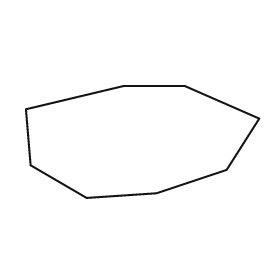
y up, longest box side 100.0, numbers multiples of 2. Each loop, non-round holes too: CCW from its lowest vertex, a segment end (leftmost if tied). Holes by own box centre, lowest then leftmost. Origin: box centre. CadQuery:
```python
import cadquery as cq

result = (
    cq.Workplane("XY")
    .moveTo(-24.0, -24.0)
    .lineTo(6.0, -22.0)
    .lineTo(36.0, -12.0)
    .lineTo(50.0, 10.0)
    .lineTo(18.0, 24.0)
    .lineTo(-8.0, 24.0)
    .lineTo(-50.0, 14.0)
    .lineTo(-48.0, -10.0)
    .close()
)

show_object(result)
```